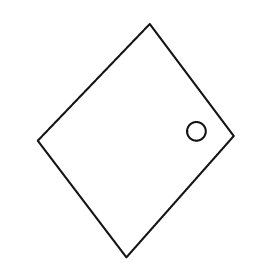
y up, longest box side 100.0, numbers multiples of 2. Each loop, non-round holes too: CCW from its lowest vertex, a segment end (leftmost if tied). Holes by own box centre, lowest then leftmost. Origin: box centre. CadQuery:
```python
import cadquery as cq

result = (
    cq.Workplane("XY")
    .moveTo(-4.0, -50.0)
    .lineTo(42.0, 2.0)
    .lineTo(6.0, 50.0)
    .lineTo(-42.0, 0.0)
    .close()
    .moveTo(26.0, 4.0)
    .circle(4.0)
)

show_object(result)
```